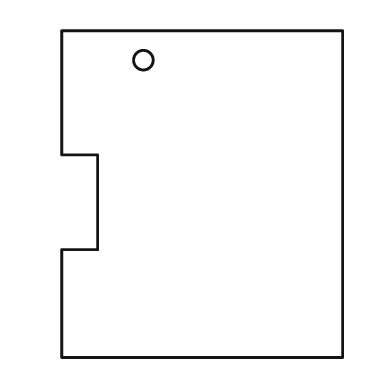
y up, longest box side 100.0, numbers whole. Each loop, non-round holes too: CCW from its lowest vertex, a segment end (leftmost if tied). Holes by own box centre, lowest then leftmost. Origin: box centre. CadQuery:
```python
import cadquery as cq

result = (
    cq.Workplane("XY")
    .moveTo(-43.0, -50.0)
    .lineTo(43.0, -50.0)
    .lineTo(43.0, 50.0)
    .lineTo(-43.0, 50.0)
    .lineTo(-43.0, 12.0)
    .lineTo(-32.0, 12.0)
    .lineTo(-32.0, -17.0)
    .lineTo(-43.0, -17.0)
    .close()
    .moveTo(-18.0, 41.0)
    .circle(3.0)
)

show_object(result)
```